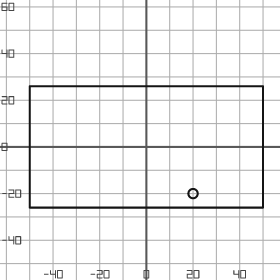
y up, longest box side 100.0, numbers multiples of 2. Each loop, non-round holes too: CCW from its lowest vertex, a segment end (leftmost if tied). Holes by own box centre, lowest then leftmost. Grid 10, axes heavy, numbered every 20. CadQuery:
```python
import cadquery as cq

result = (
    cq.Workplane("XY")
    .moveTo(-50.0, -26.0)
    .lineTo(50.0, -26.0)
    .lineTo(50.0, 26.0)
    .lineTo(-50.0, 26.0)
    .close()
    .moveTo(20.0, -20.0)
    .circle(2.0)
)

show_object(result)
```